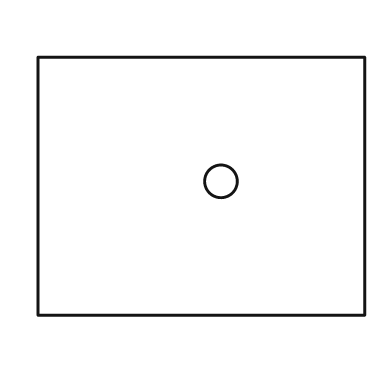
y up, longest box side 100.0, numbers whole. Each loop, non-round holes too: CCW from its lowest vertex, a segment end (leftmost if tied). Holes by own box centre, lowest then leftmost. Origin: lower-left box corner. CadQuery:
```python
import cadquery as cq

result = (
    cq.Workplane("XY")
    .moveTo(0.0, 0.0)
    .lineTo(100.0, 0.0)
    .lineTo(100.0, 79.0)
    .lineTo(0.0, 79.0)
    .close()
    .moveTo(56.0, 41.0)
    .circle(5.0)
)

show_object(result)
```